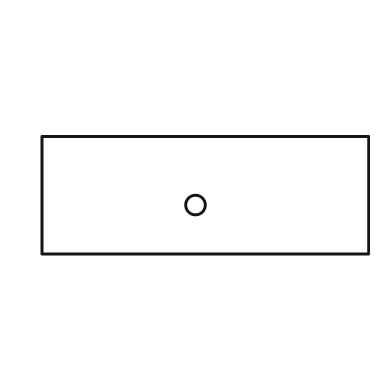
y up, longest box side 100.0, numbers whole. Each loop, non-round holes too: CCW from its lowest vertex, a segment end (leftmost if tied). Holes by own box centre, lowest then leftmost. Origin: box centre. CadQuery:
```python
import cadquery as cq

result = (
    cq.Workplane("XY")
    .moveTo(-50.0, -18.0)
    .lineTo(50.0, -18.0)
    .lineTo(50.0, 18.0)
    .lineTo(-50.0, 18.0)
    .close()
    .moveTo(-3.0, -3.0)
    .circle(3.0)
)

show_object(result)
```